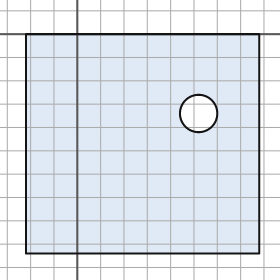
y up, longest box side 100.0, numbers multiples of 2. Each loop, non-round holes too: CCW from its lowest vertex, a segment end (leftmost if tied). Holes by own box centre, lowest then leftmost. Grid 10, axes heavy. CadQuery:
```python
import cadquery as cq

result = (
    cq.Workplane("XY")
    .moveTo(-22.0, -94.0)
    .lineTo(78.0, -94.0)
    .lineTo(78.0, 0.0)
    .lineTo(-22.0, 0.0)
    .close()
    .moveTo(52.0, -34.0)
    .circle(8.0)
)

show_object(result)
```